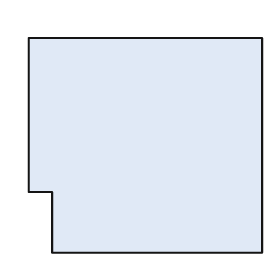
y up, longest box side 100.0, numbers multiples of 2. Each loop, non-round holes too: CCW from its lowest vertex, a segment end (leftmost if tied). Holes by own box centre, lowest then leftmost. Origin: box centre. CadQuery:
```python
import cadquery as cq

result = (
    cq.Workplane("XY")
    .moveTo(-40.0, -46.0)
    .lineTo(50.0, -46.0)
    .lineTo(50.0, 46.0)
    .lineTo(-50.0, 46.0)
    .lineTo(-50.0, -20.0)
    .lineTo(-40.0, -20.0)
    .close()
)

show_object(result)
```